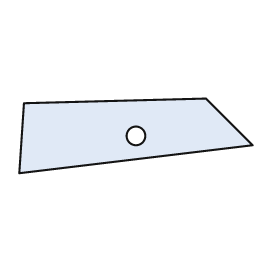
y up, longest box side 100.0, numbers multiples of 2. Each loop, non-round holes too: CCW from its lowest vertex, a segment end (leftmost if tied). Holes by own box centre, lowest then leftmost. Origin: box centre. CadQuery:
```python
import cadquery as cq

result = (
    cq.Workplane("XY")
    .moveTo(-50.0, -16.0)
    .lineTo(50.0, -4.0)
    .lineTo(30.0, 16.0)
    .lineTo(-48.0, 14.0)
    .close()
    .moveTo(0.0, 0.0)
    .circle(4.0)
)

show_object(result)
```